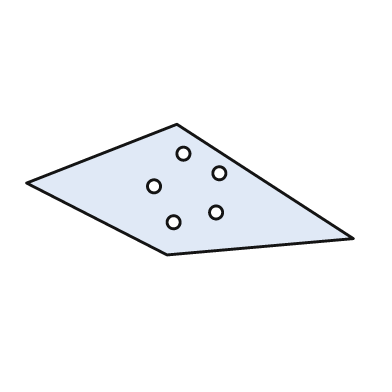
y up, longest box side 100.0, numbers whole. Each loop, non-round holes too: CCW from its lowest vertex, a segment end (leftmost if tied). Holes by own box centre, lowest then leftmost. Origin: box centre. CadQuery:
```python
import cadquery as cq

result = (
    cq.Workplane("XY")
    .moveTo(-7.0, -20.0)
    .lineTo(50.0, -15.0)
    .lineTo(-4.0, 20.0)
    .lineTo(-50.0, 2.0)
    .close()
    .moveTo(-5.0, -10.0)
    .circle(2.0)
    .moveTo(8.0, -7.0)
    .circle(2.0)
    .moveTo(-11.0, 1.0)
    .circle(2.0)
    .moveTo(9.0, 5.0)
    .circle(2.0)
    .moveTo(-2.0, 11.0)
    .circle(2.0)
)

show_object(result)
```